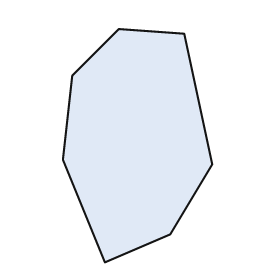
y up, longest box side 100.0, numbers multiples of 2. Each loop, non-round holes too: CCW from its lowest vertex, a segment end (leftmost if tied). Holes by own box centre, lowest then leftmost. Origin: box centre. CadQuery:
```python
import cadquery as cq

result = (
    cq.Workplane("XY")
    .moveTo(-14.0, -50.0)
    .lineTo(14.0, -38.0)
    .lineTo(32.0, -8.0)
    .lineTo(20.0, 48.0)
    .lineTo(-8.0, 50.0)
    .lineTo(-28.0, 30.0)
    .lineTo(-32.0, -6.0)
    .close()
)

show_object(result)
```